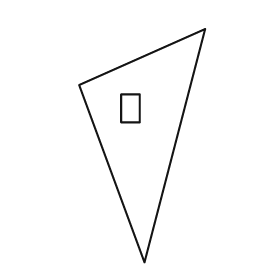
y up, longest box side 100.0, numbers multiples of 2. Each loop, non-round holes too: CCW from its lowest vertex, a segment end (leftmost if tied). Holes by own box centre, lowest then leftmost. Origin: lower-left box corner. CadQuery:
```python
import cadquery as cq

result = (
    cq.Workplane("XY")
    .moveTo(28.0, 0.0)
    .lineTo(54.0, 100.0)
    .lineTo(0.0, 76.0)
    .close()
    .moveTo(18.0, 60.0)
    .lineTo(26.0, 60.0)
    .lineTo(26.0, 72.0)
    .lineTo(18.0, 72.0)
    .close()
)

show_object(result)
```